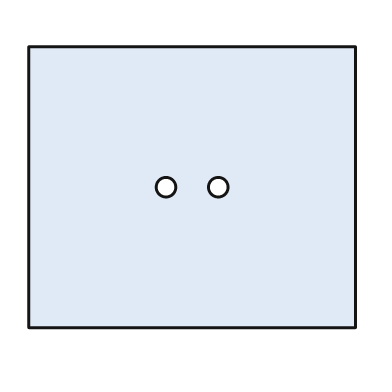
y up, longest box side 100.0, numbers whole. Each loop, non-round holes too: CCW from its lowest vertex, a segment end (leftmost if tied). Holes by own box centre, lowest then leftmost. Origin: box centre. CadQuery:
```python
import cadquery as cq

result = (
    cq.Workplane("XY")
    .moveTo(-50.0, -43.0)
    .lineTo(50.0, -43.0)
    .lineTo(50.0, 43.0)
    .lineTo(-50.0, 43.0)
    .close()
    .moveTo(-8.0, 0.0)
    .circle(3.0)
    .moveTo(8.0, 0.0)
    .circle(3.0)
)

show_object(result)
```